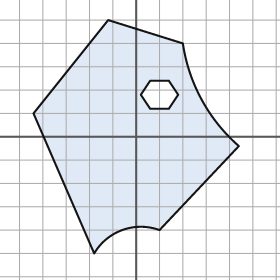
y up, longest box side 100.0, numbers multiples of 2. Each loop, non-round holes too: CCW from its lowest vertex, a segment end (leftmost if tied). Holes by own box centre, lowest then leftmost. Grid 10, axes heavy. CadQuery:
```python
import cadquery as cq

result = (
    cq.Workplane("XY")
    .moveTo(-18.0, -50.0)
    .threePointArc((-6.0, -40.0), (10.0, -40.0))
    .lineTo(44.0, -4.0)
    .threePointArc((28.0, 16.0), (20.0, 40.0))
    .lineTo(-12.0, 50.0)
    .lineTo(-44.0, 10.0)
    .close()
    .moveTo(6.0, 12.0)
    .lineTo(14.0, 12.0)
    .lineTo(18.0, 18.0)
    .lineTo(14.0, 24.0)
    .lineTo(6.0, 24.0)
    .lineTo(2.0, 18.0)
    .close()
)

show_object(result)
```